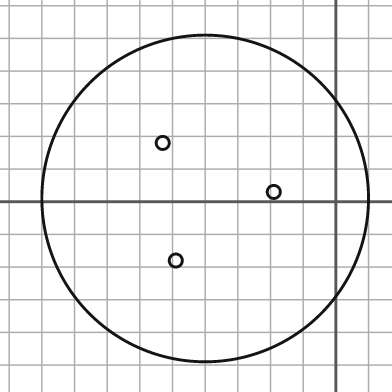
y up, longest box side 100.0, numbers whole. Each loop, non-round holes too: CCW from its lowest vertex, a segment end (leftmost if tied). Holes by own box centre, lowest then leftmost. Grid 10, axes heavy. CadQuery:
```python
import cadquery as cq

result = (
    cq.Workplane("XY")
    .moveTo(-40.0, 1.0)
    .circle(50.0)
    .moveTo(-49.0, -18.0)
    .circle(2.0)
    .moveTo(-19.0, 3.0)
    .circle(2.0)
    .moveTo(-53.0, 18.0)
    .circle(2.0)
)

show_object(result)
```